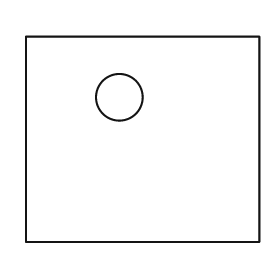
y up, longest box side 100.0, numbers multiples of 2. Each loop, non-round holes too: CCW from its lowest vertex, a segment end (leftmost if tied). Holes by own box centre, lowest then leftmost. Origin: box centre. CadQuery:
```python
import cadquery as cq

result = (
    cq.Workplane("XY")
    .moveTo(-50.0, -44.0)
    .lineTo(50.0, -44.0)
    .lineTo(50.0, 44.0)
    .lineTo(-50.0, 44.0)
    .close()
    .moveTo(-10.0, 18.0)
    .circle(10.0)
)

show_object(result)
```